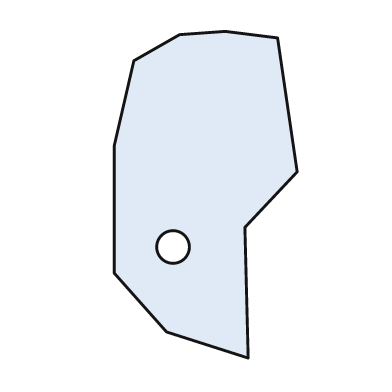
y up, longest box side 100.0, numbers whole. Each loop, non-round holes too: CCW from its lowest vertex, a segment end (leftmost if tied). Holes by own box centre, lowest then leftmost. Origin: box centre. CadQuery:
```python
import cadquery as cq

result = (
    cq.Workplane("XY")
    .moveTo(13.0, -50.0)
    .lineTo(12.0, -10.0)
    .lineTo(28.0, 7.0)
    .lineTo(22.0, 48.0)
    .lineTo(6.0, 50.0)
    .lineTo(-8.0, 49.0)
    .lineTo(-22.0, 41.0)
    .lineTo(-28.0, 15.0)
    .lineTo(-28.0, -24.0)
    .lineTo(-12.0, -42.0)
    .close()
    .moveTo(-10.0, -16.0)
    .circle(5.0)
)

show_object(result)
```